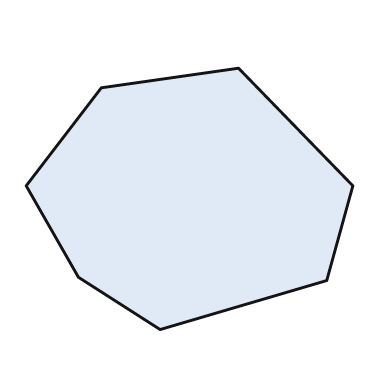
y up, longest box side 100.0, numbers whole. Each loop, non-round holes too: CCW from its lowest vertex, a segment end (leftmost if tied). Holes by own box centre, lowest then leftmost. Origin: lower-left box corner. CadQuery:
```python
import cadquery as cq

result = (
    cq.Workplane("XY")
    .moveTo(41.0, 0.0)
    .lineTo(92.0, 15.0)
    .lineTo(100.0, 44.0)
    .lineTo(65.0, 80.0)
    .lineTo(23.0, 74.0)
    .lineTo(0.0, 44.0)
    .lineTo(16.0, 16.0)
    .close()
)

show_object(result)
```